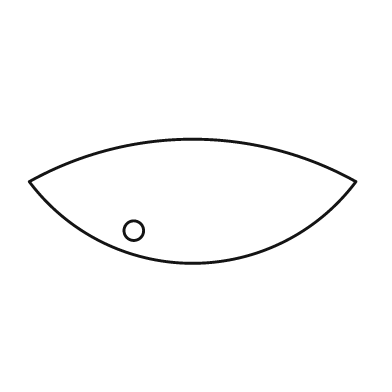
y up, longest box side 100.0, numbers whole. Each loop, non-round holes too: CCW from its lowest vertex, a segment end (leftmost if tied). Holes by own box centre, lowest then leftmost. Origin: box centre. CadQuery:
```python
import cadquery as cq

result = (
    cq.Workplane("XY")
    .moveTo(-50.0, 6.0)
    .threePointArc((0.0, -19.0), (50.0, 6.0))
    .threePointArc((0.0, 19.0), (-50.0, 6.0))
    .close()
    .moveTo(-18.0, -9.0)
    .circle(3.0)
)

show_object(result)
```